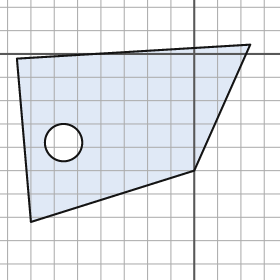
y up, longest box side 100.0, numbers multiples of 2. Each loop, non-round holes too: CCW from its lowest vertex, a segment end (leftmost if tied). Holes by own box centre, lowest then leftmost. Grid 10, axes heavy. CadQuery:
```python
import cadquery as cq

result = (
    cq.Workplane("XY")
    .moveTo(-70.0, -72.0)
    .lineTo(0.0, -50.0)
    .lineTo(24.0, 4.0)
    .lineTo(-76.0, -2.0)
    .close()
    .moveTo(-56.0, -38.0)
    .circle(8.0)
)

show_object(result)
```